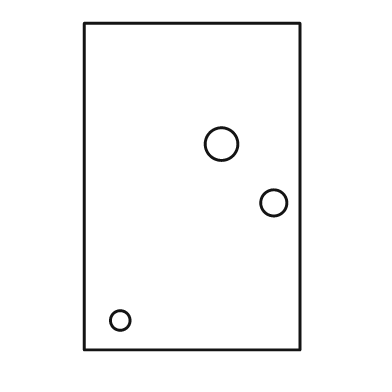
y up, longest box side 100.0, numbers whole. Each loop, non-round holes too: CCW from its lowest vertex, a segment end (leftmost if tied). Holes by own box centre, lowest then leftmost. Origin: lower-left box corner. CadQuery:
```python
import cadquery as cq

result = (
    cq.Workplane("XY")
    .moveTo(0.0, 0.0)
    .lineTo(66.0, 0.0)
    .lineTo(66.0, 100.0)
    .lineTo(0.0, 100.0)
    .close()
    .moveTo(11.0, 9.0)
    .circle(3.0)
    .moveTo(58.0, 45.0)
    .circle(4.0)
    .moveTo(42.0, 63.0)
    .circle(5.0)
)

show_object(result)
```